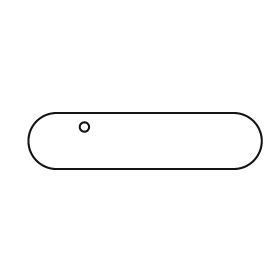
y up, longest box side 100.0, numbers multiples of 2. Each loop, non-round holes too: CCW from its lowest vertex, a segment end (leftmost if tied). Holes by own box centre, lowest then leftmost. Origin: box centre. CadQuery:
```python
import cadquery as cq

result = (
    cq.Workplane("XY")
    .moveTo(-38.0, -12.0)
    .lineTo(38.0, -12.0)
    .threePointArc((50.0, 0.0), (38.0, 12.0))
    .lineTo(-38.0, 12.0)
    .threePointArc((-50.0, 0.0), (-38.0, -12.0))
    .close()
    .moveTo(-26.0, 6.0)
    .circle(2.0)
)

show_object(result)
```